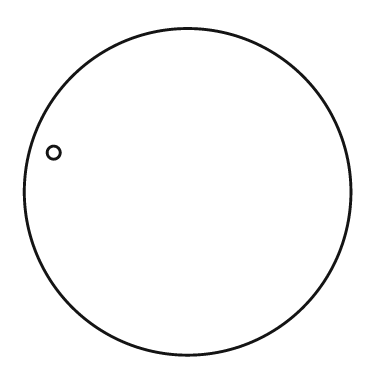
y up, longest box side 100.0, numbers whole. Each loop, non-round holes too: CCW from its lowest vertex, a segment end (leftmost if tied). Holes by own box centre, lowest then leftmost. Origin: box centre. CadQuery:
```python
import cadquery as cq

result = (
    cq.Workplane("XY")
    .moveTo(0.0, 0.0)
    .circle(50.0)
    .moveTo(-41.0, 12.0)
    .circle(2.0)
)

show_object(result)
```